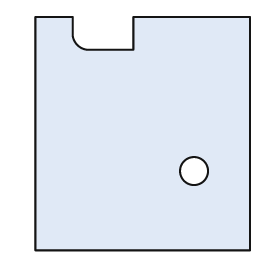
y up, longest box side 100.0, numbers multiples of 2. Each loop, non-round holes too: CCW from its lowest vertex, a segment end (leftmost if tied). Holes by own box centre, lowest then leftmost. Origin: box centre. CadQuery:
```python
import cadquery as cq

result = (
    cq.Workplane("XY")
    .moveTo(-46.0, -50.0)
    .lineTo(46.0, -50.0)
    .lineTo(46.0, 50.0)
    .lineTo(-4.0, 50.0)
    .lineTo(-4.0, 36.0)
    .lineTo(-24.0, 36.0)
    .threePointArc((-28.0, 38.0), (-30.0, 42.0))
    .lineTo(-30.0, 50.0)
    .lineTo(-46.0, 50.0)
    .close()
    .moveTo(22.0, -16.0)
    .circle(6.0)
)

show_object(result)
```